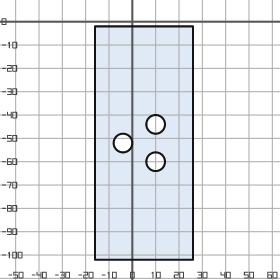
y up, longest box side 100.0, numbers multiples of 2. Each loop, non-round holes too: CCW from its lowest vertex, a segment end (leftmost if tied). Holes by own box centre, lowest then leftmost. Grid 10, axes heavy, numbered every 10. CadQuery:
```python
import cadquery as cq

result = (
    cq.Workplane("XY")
    .moveTo(-16.0, -102.0)
    .lineTo(26.0, -102.0)
    .lineTo(26.0, -2.0)
    .lineTo(-16.0, -2.0)
    .close()
    .moveTo(10.0, -60.0)
    .circle(4.0)
    .moveTo(-4.0, -52.0)
    .circle(4.0)
    .moveTo(10.0, -44.0)
    .circle(4.0)
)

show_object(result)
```